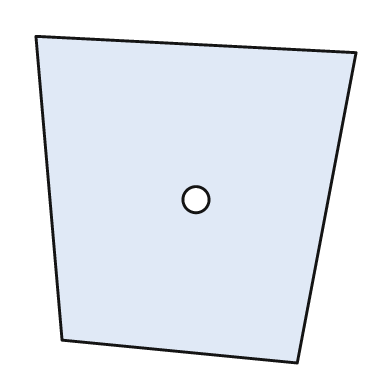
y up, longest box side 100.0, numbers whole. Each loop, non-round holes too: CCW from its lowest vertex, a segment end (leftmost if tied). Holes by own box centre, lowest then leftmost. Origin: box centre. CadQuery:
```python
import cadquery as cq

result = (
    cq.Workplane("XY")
    .moveTo(31.0, -50.0)
    .lineTo(49.0, 45.0)
    .lineTo(-49.0, 50.0)
    .lineTo(-41.0, -43.0)
    .close()
    .moveTo(0.0, 0.0)
    .circle(4.0)
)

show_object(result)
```